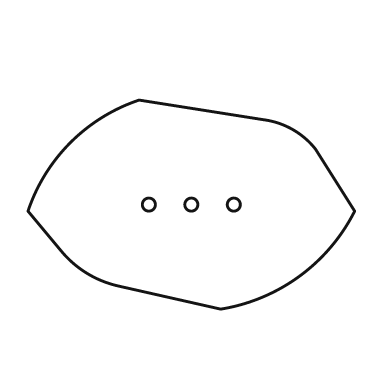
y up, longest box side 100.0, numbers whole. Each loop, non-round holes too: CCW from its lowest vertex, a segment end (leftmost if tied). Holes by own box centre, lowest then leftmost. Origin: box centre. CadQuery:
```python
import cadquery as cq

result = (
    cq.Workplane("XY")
    .moveTo(9.0, -32.0)
    .threePointArc((33.0, -22.0), (50.0, -2.0))
    .lineTo(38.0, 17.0)
    .threePointArc((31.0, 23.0), (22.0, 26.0))
    .lineTo(-16.0, 32.0)
    .threePointArc((-37.0, 19.0), (-50.0, -2.0))
    .lineTo(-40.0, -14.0)
    .threePointArc((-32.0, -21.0), (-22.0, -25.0))
    .close()
    .moveTo(-13.0, 0.0)
    .circle(2.0)
    .moveTo(0.0, 0.0)
    .circle(2.0)
    .moveTo(13.0, 0.0)
    .circle(2.0)
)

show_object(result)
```